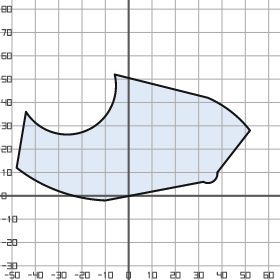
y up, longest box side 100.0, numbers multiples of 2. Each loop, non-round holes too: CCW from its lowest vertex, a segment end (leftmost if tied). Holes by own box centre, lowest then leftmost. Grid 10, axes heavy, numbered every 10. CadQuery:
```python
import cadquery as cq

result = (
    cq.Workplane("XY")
    .moveTo(-10.0, -2.0)
    .lineTo(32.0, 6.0)
    .threePointArc((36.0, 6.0), (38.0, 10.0))
    .lineTo(52.0, 28.0)
    .threePointArc((44.0, 36.0), (34.0, 42.0))
    .lineTo(-6.0, 52.0)
    .threePointArc((-18.0, 28.0), (-44.0, 36.0))
    .lineTo(-48.0, 12.0)
    .threePointArc((-30.0, 2.0), (-10.0, -2.0))
    .close()
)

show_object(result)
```